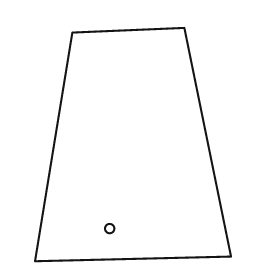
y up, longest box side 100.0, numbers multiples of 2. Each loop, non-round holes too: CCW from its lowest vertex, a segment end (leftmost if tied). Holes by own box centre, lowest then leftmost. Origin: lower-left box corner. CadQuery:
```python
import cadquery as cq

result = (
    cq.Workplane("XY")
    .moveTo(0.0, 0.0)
    .lineTo(84.0, 2.0)
    .lineTo(64.0, 100.0)
    .lineTo(16.0, 98.0)
    .close()
    .moveTo(32.0, 14.0)
    .circle(2.0)
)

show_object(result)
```